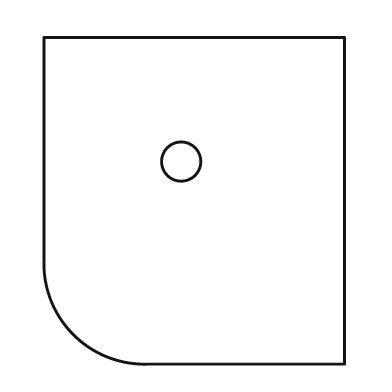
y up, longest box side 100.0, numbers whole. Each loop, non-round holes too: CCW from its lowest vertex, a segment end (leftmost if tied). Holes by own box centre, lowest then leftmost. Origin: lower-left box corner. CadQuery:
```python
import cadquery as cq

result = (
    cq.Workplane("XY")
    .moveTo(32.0, 0.0)
    .lineTo(92.0, 0.0)
    .lineTo(92.0, 100.0)
    .lineTo(0.0, 100.0)
    .lineTo(0.0, 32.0)
    .threePointArc((9.0, 9.0), (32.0, 0.0))
    .close()
    .moveTo(42.0, 62.0)
    .circle(6.0)
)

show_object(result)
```